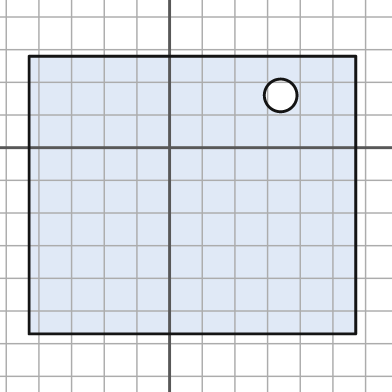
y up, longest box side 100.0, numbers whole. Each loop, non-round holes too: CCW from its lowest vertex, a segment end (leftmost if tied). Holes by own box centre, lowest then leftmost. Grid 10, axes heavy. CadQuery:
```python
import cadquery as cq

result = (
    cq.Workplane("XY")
    .moveTo(-43.0, -57.0)
    .lineTo(57.0, -57.0)
    .lineTo(57.0, 28.0)
    .lineTo(-43.0, 28.0)
    .close()
    .moveTo(34.0, 16.0)
    .circle(5.0)
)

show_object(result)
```